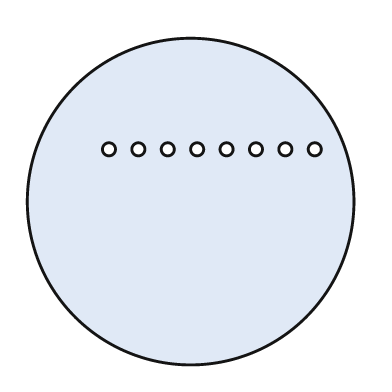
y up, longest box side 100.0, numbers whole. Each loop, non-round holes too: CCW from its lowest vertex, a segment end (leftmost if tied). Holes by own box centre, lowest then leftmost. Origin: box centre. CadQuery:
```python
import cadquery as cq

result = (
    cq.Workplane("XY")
    .moveTo(0.0, 0.0)
    .circle(50.0)
    .moveTo(-25.0, 16.0)
    .circle(2.0)
    .moveTo(-16.0, 16.0)
    .circle(2.0)
    .moveTo(-7.0, 16.0)
    .circle(2.0)
    .moveTo(2.0, 16.0)
    .circle(2.0)
    .moveTo(11.0, 16.0)
    .circle(2.0)
    .moveTo(20.0, 16.0)
    .circle(2.0)
    .moveTo(29.0, 16.0)
    .circle(2.0)
    .moveTo(38.0, 16.0)
    .circle(2.0)
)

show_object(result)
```